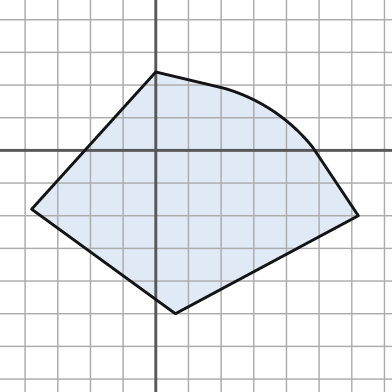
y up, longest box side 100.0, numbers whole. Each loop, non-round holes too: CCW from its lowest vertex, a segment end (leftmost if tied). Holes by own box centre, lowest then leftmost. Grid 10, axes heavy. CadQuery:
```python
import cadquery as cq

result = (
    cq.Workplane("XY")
    .moveTo(6.0, -50.0)
    .lineTo(62.0, -20.0)
    .lineTo(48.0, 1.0)
    .threePointArc((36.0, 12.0), (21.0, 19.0))
    .lineTo(0.0, 24.0)
    .lineTo(-38.0, -18.0)
    .close()
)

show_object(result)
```